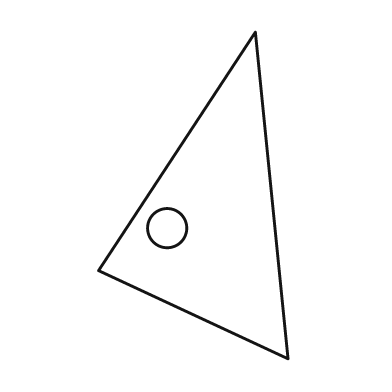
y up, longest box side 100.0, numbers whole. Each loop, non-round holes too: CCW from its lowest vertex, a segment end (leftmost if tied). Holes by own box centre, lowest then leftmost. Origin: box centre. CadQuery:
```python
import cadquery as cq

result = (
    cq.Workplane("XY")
    .moveTo(29.0, -50.0)
    .lineTo(19.0, 50.0)
    .lineTo(-29.0, -23.0)
    .close()
    .moveTo(-8.0, -10.0)
    .circle(6.0)
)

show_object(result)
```